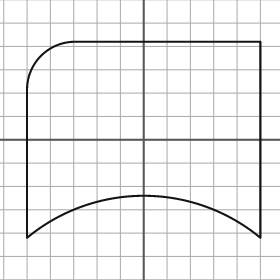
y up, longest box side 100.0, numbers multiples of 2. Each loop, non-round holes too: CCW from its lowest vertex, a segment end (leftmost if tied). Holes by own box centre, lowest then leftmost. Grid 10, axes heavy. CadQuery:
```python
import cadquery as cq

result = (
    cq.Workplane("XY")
    .moveTo(-50.0, -42.0)
    .threePointArc((0.0, -24.0), (50.0, -42.0))
    .lineTo(50.0, 42.0)
    .lineTo(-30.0, 42.0)
    .threePointArc((-44.0, 36.0), (-50.0, 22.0))
    .close()
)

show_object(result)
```